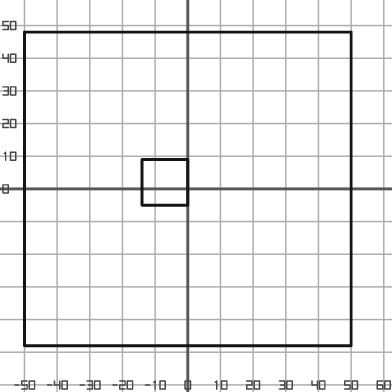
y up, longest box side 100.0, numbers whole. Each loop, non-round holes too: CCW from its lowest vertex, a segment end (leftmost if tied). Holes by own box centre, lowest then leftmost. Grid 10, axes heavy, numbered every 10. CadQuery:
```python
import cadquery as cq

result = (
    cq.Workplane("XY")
    .moveTo(-50.0, -48.0)
    .lineTo(50.0, -48.0)
    .lineTo(50.0, 48.0)
    .lineTo(-50.0, 48.0)
    .close()
    .moveTo(-14.0, -5.0)
    .lineTo(0.0, -5.0)
    .lineTo(0.0, 9.0)
    .lineTo(-14.0, 9.0)
    .close()
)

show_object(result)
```